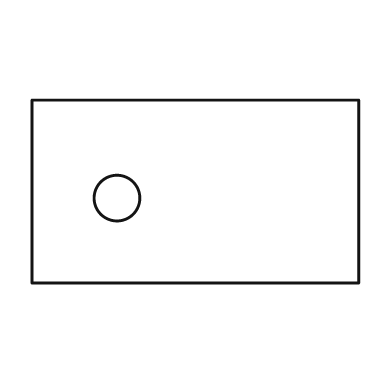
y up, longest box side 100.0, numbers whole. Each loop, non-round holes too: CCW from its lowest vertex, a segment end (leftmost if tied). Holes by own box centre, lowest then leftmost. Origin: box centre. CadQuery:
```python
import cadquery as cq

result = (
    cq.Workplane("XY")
    .moveTo(-50.0, -28.0)
    .lineTo(50.0, -28.0)
    .lineTo(50.0, 28.0)
    .lineTo(-50.0, 28.0)
    .close()
    .moveTo(-24.0, -2.0)
    .circle(7.0)
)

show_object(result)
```